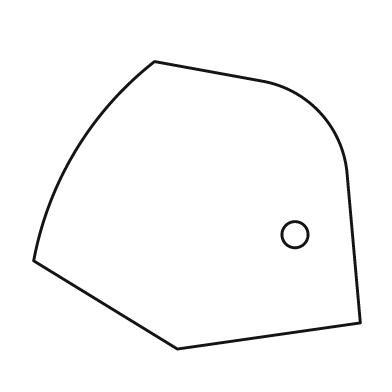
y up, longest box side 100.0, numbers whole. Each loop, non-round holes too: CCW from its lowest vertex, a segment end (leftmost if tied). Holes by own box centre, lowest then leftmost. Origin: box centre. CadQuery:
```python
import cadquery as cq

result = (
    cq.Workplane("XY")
    .moveTo(-6.0, -44.0)
    .lineTo(50.0, -36.0)
    .lineTo(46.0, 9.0)
    .threePointArc((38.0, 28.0), (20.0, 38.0))
    .lineTo(-13.0, 44.0)
    .threePointArc((-37.0, 17.0), (-50.0, -17.0))
    .close()
    .moveTo(30.0, -9.0)
    .circle(4.0)
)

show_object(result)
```